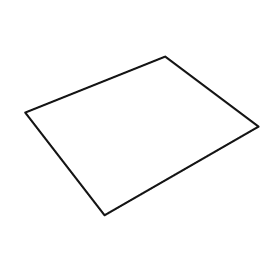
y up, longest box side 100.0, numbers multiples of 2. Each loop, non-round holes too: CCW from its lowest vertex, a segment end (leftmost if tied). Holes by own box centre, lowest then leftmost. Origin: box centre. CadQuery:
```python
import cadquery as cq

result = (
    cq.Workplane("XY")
    .moveTo(-16.0, -34.0)
    .lineTo(50.0, 4.0)
    .lineTo(10.0, 34.0)
    .lineTo(-50.0, 10.0)
    .close()
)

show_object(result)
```